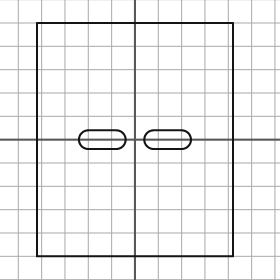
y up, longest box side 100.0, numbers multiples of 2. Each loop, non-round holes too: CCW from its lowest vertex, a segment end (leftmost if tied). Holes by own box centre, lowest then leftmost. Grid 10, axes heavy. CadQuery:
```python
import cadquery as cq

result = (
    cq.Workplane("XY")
    .moveTo(-42.0, -50.0)
    .lineTo(42.0, -50.0)
    .lineTo(42.0, 50.0)
    .lineTo(-42.0, 50.0)
    .close()
    .moveTo(-20.0, -4.0)
    .lineTo(-8.0, -4.0)
    .threePointArc((-4.0, 0.0), (-8.0, 4.0))
    .lineTo(-20.0, 4.0)
    .threePointArc((-24.0, 0.0), (-20.0, -4.0))
    .close()
    .moveTo(8.0, -4.0)
    .lineTo(20.0, -4.0)
    .threePointArc((24.0, 0.0), (20.0, 4.0))
    .lineTo(8.0, 4.0)
    .threePointArc((4.0, 0.0), (8.0, -4.0))
    .close()
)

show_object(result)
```